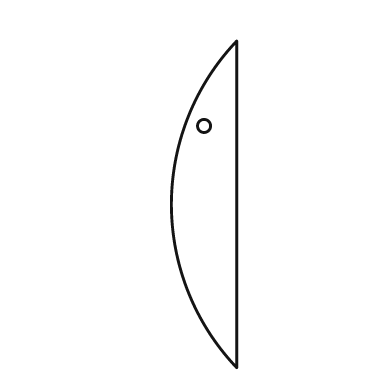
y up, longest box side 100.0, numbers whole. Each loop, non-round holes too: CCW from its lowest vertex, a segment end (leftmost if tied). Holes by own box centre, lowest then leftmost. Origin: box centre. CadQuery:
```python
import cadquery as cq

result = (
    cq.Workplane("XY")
    .moveTo(10.0, -50.0)
    .lineTo(10.0, 50.0)
    .threePointArc((-10.0, 0.0), (10.0, -50.0))
    .close()
    .moveTo(0.0, 24.0)
    .circle(2.0)
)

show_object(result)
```